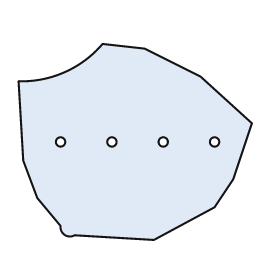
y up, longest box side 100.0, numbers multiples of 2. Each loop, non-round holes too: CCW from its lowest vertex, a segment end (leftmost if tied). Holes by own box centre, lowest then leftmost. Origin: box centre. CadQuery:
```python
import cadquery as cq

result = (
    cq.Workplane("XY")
    .moveTo(8.0, -42.0)
    .lineTo(34.0, -28.0)
    .lineTo(42.0, -16.0)
    .lineTo(50.0, 8.0)
    .lineTo(28.0, 28.0)
    .lineTo(4.0, 40.0)
    .lineTo(-14.0, 42.0)
    .threePointArc((-30.0, 30.0), (-50.0, 26.0))
    .lineTo(-48.0, -8.0)
    .lineTo(-42.0, -24.0)
    .lineTo(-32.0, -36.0)
    .threePointArc((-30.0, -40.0), (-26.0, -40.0))
    .close()
    .moveTo(-32.0, 0.0)
    .circle(2.0)
    .moveTo(-10.0, 0.0)
    .circle(2.0)
    .moveTo(12.0, 0.0)
    .circle(2.0)
    .moveTo(34.0, 0.0)
    .circle(2.0)
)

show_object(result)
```